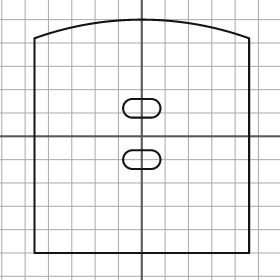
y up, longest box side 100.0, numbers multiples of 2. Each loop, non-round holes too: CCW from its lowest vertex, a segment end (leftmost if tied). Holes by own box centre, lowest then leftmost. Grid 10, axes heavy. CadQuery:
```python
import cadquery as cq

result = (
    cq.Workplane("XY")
    .moveTo(-46.0, -50.0)
    .lineTo(46.0, -50.0)
    .lineTo(46.0, 42.0)
    .threePointArc((0.0, 50.0), (-46.0, 42.0))
    .close()
    .moveTo(-4.0, -14.0)
    .lineTo(4.0, -14.0)
    .threePointArc((8.0, -10.0), (4.0, -6.0))
    .lineTo(-4.0, -6.0)
    .threePointArc((-8.0, -10.0), (-4.0, -14.0))
    .close()
    .moveTo(-4.0, 8.0)
    .lineTo(4.0, 8.0)
    .threePointArc((8.0, 12.0), (4.0, 16.0))
    .lineTo(-4.0, 16.0)
    .threePointArc((-8.0, 12.0), (-4.0, 8.0))
    .close()
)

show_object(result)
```